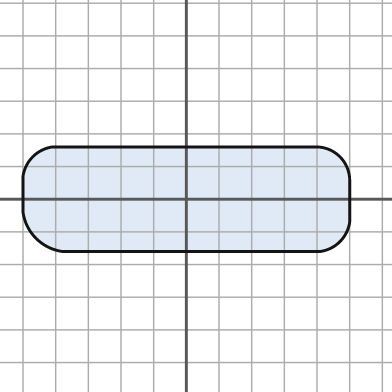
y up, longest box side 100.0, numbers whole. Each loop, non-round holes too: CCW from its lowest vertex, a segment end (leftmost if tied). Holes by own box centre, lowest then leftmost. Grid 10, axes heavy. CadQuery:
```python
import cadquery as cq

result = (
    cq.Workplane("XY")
    .moveTo(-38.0, -16.0)
    .lineTo(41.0, -16.0)
    .threePointArc((47.0, -13.0), (50.0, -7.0))
    .lineTo(50.0, 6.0)
    .threePointArc((47.0, 13.0), (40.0, 16.0))
    .lineTo(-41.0, 16.0)
    .threePointArc((-47.0, 13.0), (-50.0, 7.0))
    .lineTo(-50.0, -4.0)
    .threePointArc((-46.0, -12.0), (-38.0, -16.0))
    .close()
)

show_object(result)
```